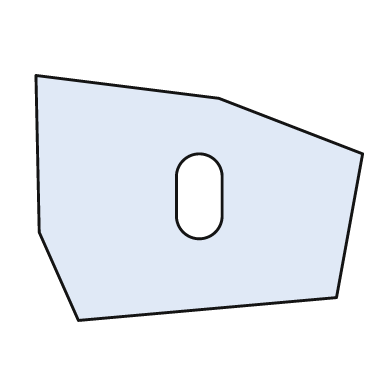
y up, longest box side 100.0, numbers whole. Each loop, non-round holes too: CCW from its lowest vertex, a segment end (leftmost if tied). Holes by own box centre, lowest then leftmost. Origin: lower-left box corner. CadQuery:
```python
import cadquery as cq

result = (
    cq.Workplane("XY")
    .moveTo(13.0, 0.0)
    .lineTo(92.0, 7.0)
    .lineTo(100.0, 51.0)
    .lineTo(56.0, 68.0)
    .lineTo(0.0, 75.0)
    .lineTo(1.0, 27.0)
    .close()
    .moveTo(43.0, 32.0)
    .threePointArc((50.0, 25.0), (57.0, 32.0))
    .lineTo(57.0, 44.0)
    .threePointArc((50.0, 51.0), (43.0, 44.0))
    .close()
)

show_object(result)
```